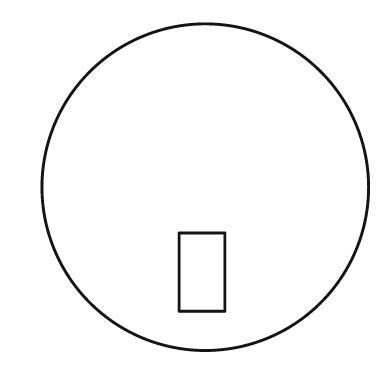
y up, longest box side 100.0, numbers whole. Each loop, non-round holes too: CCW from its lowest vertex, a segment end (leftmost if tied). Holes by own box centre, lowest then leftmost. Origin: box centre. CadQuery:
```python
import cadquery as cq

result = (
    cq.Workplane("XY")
    .moveTo(0.0, 0.0)
    .circle(50.0)
    .moveTo(-8.0, -38.0)
    .lineTo(6.0, -38.0)
    .lineTo(6.0, -14.0)
    .lineTo(-8.0, -14.0)
    .close()
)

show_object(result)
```